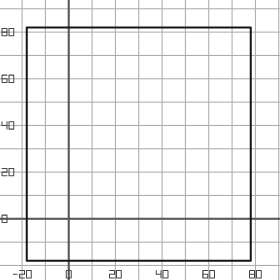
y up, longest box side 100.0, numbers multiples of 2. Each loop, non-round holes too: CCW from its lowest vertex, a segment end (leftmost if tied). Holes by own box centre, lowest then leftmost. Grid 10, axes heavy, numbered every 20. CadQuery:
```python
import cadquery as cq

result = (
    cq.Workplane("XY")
    .moveTo(-18.0, -18.0)
    .lineTo(78.0, -18.0)
    .lineTo(78.0, 82.0)
    .lineTo(-18.0, 82.0)
    .close()
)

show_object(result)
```